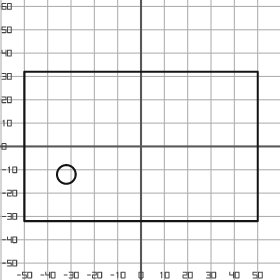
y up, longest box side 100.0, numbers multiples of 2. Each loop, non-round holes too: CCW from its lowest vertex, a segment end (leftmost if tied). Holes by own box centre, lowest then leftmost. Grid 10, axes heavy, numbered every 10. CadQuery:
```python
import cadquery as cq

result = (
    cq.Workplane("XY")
    .moveTo(-50.0, -32.0)
    .lineTo(50.0, -32.0)
    .lineTo(50.0, 32.0)
    .lineTo(-50.0, 32.0)
    .close()
    .moveTo(-32.0, -12.0)
    .circle(4.0)
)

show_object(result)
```